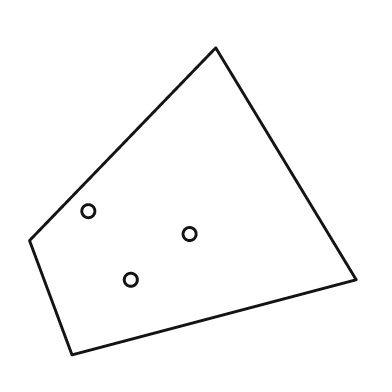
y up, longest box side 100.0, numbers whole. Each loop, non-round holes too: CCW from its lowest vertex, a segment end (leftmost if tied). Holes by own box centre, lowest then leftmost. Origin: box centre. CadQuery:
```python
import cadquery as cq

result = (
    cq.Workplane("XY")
    .moveTo(-37.0, -47.0)
    .lineTo(50.0, -24.0)
    .lineTo(7.0, 47.0)
    .lineTo(-50.0, -12.0)
    .close()
    .moveTo(-19.0, -24.0)
    .circle(2.0)
    .moveTo(-1.0, -10.0)
    .circle(2.0)
    .moveTo(-32.0, -3.0)
    .circle(2.0)
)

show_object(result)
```